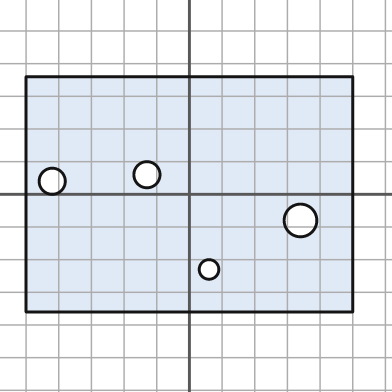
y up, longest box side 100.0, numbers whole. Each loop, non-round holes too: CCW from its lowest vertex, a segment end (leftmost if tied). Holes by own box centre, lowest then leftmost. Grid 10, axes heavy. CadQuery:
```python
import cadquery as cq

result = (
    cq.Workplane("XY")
    .moveTo(-50.0, -36.0)
    .lineTo(50.0, -36.0)
    .lineTo(50.0, 36.0)
    .lineTo(-50.0, 36.0)
    .close()
    .moveTo(6.0, -23.0)
    .circle(3.0)
    .moveTo(34.0, -8.0)
    .circle(5.0)
    .moveTo(-42.0, 4.0)
    .circle(4.0)
    .moveTo(-13.0, 6.0)
    .circle(4.0)
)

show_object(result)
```